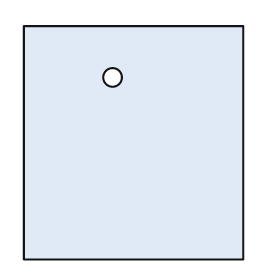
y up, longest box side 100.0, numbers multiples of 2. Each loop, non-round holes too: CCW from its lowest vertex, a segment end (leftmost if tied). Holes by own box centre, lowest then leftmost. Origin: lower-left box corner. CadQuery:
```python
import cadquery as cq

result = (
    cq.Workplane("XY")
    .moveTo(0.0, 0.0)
    .lineTo(94.0, 0.0)
    .lineTo(94.0, 100.0)
    .lineTo(0.0, 100.0)
    .close()
    .moveTo(38.0, 78.0)
    .circle(4.0)
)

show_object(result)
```